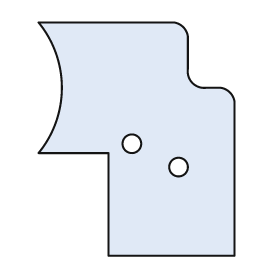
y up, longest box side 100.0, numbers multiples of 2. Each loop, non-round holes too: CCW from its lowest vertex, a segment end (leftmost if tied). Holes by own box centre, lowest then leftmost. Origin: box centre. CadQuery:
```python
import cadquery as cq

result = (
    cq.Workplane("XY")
    .moveTo(-12.0, -50.0)
    .lineTo(42.0, -50.0)
    .lineTo(42.0, 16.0)
    .threePointArc((40.0, 20.0), (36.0, 22.0))
    .lineTo(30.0, 22.0)
    .threePointArc((24.0, 24.0), (22.0, 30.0))
    .lineTo(22.0, 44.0)
    .threePointArc((20.0, 48.0), (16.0, 50.0))
    .lineTo(-42.0, 50.0)
    .threePointArc((-32.0, 22.0), (-42.0, -6.0))
    .lineTo(-12.0, -6.0)
    .close()
    .moveTo(18.0, -12.0)
    .circle(4.0)
    .moveTo(-2.0, -2.0)
    .circle(4.0)
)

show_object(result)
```